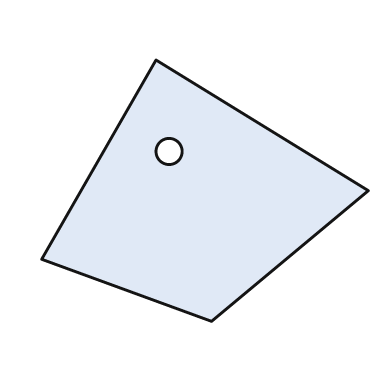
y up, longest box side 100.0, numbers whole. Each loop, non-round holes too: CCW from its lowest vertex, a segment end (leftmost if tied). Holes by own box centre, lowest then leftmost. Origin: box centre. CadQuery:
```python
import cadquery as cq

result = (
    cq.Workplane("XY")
    .moveTo(2.0, -40.0)
    .lineTo(50.0, 0.0)
    .lineTo(-15.0, 40.0)
    .lineTo(-50.0, -21.0)
    .close()
    .moveTo(-11.0, 12.0)
    .circle(4.0)
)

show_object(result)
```